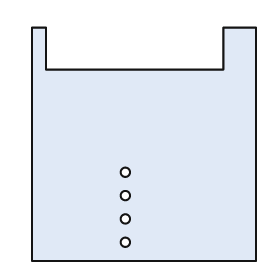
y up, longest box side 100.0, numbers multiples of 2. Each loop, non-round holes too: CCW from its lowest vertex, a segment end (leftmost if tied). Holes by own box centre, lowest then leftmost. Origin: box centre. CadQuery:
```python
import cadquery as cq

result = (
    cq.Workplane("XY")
    .moveTo(-48.0, -50.0)
    .lineTo(48.0, -50.0)
    .lineTo(48.0, 50.0)
    .lineTo(34.0, 50.0)
    .lineTo(34.0, 32.0)
    .lineTo(-42.0, 32.0)
    .lineTo(-42.0, 50.0)
    .lineTo(-48.0, 50.0)
    .close()
    .moveTo(-8.0, -42.0)
    .circle(2.0)
    .moveTo(-8.0, -32.0)
    .circle(2.0)
    .moveTo(-8.0, -22.0)
    .circle(2.0)
    .moveTo(-8.0, -12.0)
    .circle(2.0)
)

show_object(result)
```